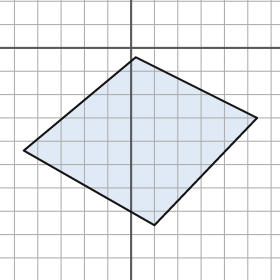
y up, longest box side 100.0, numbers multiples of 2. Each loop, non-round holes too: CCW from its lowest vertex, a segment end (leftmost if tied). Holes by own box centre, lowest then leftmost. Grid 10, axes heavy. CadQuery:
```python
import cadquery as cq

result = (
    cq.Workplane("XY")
    .moveTo(10.0, -76.0)
    .lineTo(54.0, -30.0)
    .lineTo(2.0, -4.0)
    .lineTo(-46.0, -44.0)
    .close()
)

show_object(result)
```